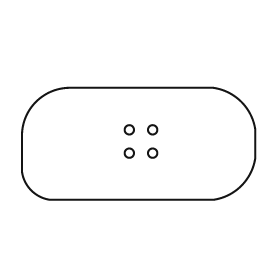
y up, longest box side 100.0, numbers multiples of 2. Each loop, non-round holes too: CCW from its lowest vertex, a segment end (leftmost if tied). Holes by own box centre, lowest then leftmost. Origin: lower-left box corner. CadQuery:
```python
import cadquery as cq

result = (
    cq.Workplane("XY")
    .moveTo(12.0, 0.0)
    .lineTo(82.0, 0.0)
    .threePointArc((94.0, 6.0), (100.0, 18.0))
    .lineTo(100.0, 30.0)
    .threePointArc((94.0, 42.0), (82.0, 48.0))
    .lineTo(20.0, 48.0)
    .threePointArc((6.0, 42.0), (0.0, 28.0))
    .lineTo(0.0, 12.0)
    .threePointArc((4.0, 4.0), (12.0, 0.0))
    .close()
    .moveTo(46.0, 20.0)
    .circle(2.0)
    .moveTo(56.0, 20.0)
    .circle(2.0)
    .moveTo(46.0, 30.0)
    .circle(2.0)
    .moveTo(56.0, 30.0)
    .circle(2.0)
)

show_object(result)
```